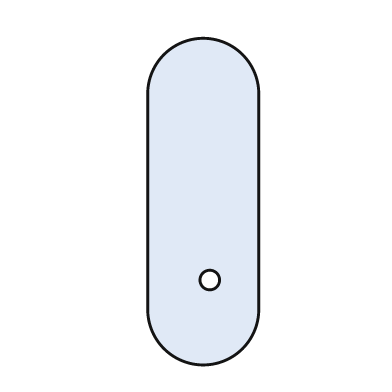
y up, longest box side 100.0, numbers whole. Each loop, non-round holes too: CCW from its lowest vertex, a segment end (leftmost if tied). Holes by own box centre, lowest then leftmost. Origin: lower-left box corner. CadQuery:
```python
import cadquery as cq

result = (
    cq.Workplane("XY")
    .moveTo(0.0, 17.0)
    .threePointArc((17.0, 0.0), (34.0, 17.0))
    .lineTo(34.0, 83.0)
    .threePointArc((17.0, 100.0), (0.0, 83.0))
    .close()
    .moveTo(19.0, 26.0)
    .circle(3.0)
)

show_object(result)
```